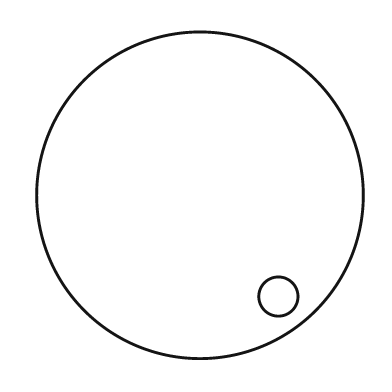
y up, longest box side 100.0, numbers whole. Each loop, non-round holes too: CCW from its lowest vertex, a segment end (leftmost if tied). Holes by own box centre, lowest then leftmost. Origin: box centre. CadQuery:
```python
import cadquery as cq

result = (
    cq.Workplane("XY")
    .moveTo(0.0, 0.0)
    .circle(50.0)
    .moveTo(24.0, -31.0)
    .circle(6.0)
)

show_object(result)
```